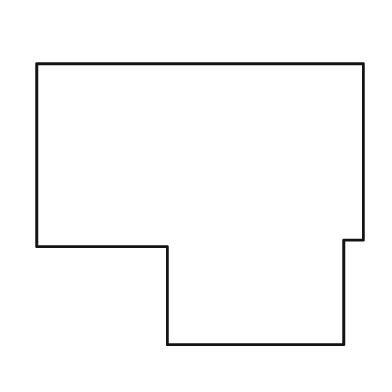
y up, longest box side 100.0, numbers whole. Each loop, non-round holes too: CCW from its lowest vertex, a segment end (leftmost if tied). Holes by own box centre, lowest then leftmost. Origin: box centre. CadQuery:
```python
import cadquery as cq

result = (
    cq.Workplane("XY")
    .moveTo(-10.0, -43.0)
    .lineTo(44.0, -43.0)
    .lineTo(44.0, -11.0)
    .lineTo(50.0, -11.0)
    .lineTo(50.0, 43.0)
    .lineTo(-50.0, 43.0)
    .lineTo(-50.0, -13.0)
    .lineTo(-10.0, -13.0)
    .close()
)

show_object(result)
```